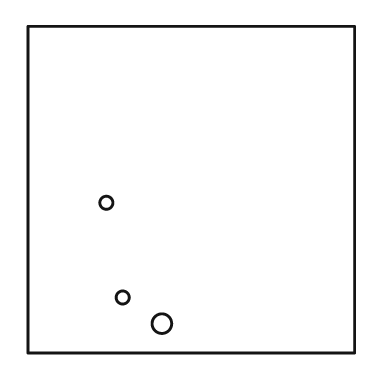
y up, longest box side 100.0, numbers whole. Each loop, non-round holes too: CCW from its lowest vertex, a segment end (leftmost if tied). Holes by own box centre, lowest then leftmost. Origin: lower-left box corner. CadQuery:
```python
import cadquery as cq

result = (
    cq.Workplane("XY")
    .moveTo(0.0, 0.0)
    .lineTo(100.0, 0.0)
    .lineTo(100.0, 100.0)
    .lineTo(0.0, 100.0)
    .close()
    .moveTo(41.0, 9.0)
    .circle(3.0)
    .moveTo(29.0, 17.0)
    .circle(2.0)
    .moveTo(24.0, 46.0)
    .circle(2.0)
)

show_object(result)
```